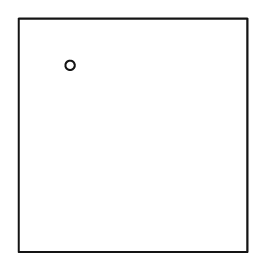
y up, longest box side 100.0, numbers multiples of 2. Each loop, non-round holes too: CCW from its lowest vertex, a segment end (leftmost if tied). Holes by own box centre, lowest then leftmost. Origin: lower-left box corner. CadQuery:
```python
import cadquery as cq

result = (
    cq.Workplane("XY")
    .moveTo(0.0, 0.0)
    .lineTo(98.0, 0.0)
    .lineTo(98.0, 100.0)
    .lineTo(0.0, 100.0)
    .close()
    .moveTo(22.0, 80.0)
    .circle(2.0)
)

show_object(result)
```